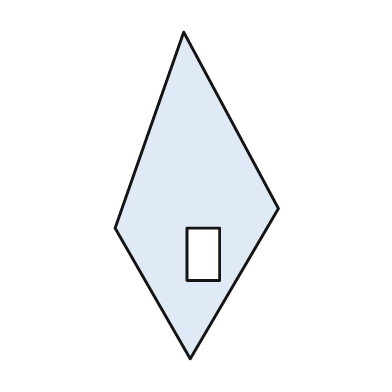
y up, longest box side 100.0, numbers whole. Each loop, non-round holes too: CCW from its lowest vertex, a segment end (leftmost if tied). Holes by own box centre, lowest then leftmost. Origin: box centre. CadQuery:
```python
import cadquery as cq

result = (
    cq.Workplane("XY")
    .moveTo(-2.0, -50.0)
    .lineTo(25.0, -4.0)
    .lineTo(-4.0, 50.0)
    .lineTo(-25.0, -10.0)
    .close()
    .moveTo(-3.0, -26.0)
    .lineTo(7.0, -26.0)
    .lineTo(7.0, -10.0)
    .lineTo(-3.0, -10.0)
    .close()
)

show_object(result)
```